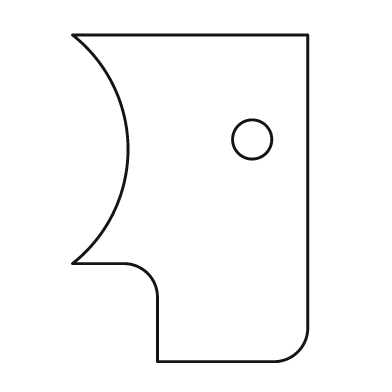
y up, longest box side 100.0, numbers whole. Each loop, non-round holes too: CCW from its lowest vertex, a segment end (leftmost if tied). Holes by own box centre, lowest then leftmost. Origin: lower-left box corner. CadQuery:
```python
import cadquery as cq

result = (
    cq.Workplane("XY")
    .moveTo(26.0, 0.0)
    .lineTo(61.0, 0.0)
    .threePointArc((69.0, 3.0), (72.0, 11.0))
    .lineTo(72.0, 100.0)
    .lineTo(0.0, 100.0)
    .threePointArc((17.0, 65.0), (0.0, 30.0))
    .lineTo(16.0, 30.0)
    .threePointArc((23.0, 27.0), (26.0, 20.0))
    .close()
    .moveTo(55.0, 68.0)
    .circle(6.0)
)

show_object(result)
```